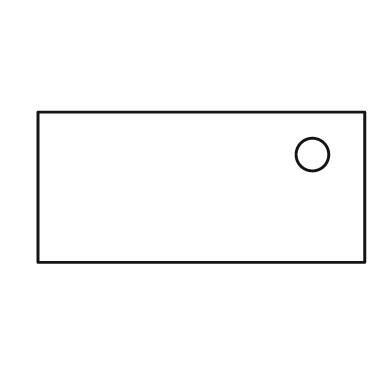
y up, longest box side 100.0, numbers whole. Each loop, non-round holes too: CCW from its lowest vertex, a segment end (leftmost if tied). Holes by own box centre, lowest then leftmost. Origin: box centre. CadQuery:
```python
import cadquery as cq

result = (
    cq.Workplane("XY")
    .moveTo(-50.0, -23.0)
    .lineTo(50.0, -23.0)
    .lineTo(50.0, 23.0)
    .lineTo(-50.0, 23.0)
    .close()
    .moveTo(34.0, 10.0)
    .circle(5.0)
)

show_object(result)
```